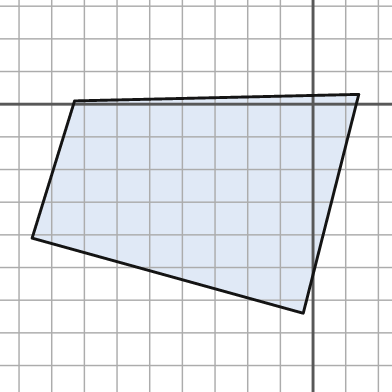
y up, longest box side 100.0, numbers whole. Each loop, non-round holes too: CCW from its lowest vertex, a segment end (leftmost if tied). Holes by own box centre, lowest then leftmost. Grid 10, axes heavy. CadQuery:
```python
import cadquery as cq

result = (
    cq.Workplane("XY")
    .moveTo(-3.0, -64.0)
    .lineTo(14.0, 3.0)
    .lineTo(-73.0, 1.0)
    .lineTo(-86.0, -41.0)
    .close()
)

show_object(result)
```